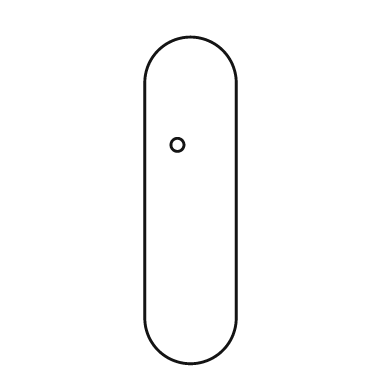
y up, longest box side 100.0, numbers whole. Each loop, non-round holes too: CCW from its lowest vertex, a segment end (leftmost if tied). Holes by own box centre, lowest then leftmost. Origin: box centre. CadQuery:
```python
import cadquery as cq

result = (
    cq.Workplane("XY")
    .moveTo(-14.0, -36.0)
    .threePointArc((0.0, -50.0), (14.0, -36.0))
    .lineTo(14.0, 36.0)
    .threePointArc((0.0, 50.0), (-14.0, 36.0))
    .close()
    .moveTo(-4.0, 17.0)
    .circle(2.0)
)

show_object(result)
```